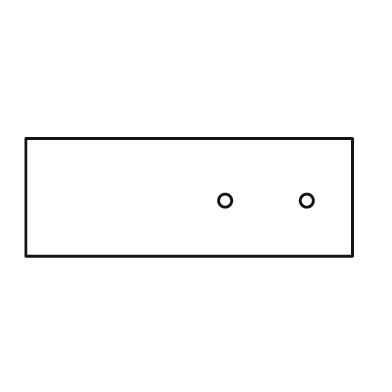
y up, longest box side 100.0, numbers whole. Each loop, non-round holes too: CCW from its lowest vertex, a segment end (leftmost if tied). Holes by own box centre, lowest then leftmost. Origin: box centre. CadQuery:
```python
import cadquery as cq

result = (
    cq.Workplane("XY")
    .moveTo(-50.0, -18.0)
    .lineTo(50.0, -18.0)
    .lineTo(50.0, 18.0)
    .lineTo(-50.0, 18.0)
    .close()
    .moveTo(11.0, -1.0)
    .circle(2.0)
    .moveTo(36.0, -1.0)
    .circle(2.0)
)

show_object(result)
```